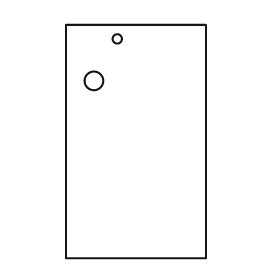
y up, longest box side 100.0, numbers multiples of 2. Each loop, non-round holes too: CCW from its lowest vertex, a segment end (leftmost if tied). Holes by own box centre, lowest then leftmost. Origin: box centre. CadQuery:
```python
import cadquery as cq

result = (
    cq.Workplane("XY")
    .moveTo(-30.0, -50.0)
    .lineTo(30.0, -50.0)
    .lineTo(30.0, 50.0)
    .lineTo(-30.0, 50.0)
    .close()
    .moveTo(-18.0, 26.0)
    .circle(4.0)
    .moveTo(-8.0, 44.0)
    .circle(2.0)
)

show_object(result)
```